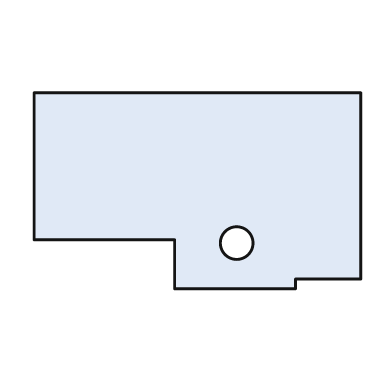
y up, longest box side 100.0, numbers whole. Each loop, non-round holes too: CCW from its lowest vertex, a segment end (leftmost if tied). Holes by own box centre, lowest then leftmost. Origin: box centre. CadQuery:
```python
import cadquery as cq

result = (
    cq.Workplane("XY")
    .moveTo(-7.0, -30.0)
    .lineTo(30.0, -30.0)
    .lineTo(30.0, -27.0)
    .lineTo(50.0, -27.0)
    .lineTo(50.0, 30.0)
    .lineTo(-50.0, 30.0)
    .lineTo(-50.0, -15.0)
    .lineTo(-7.0, -15.0)
    .close()
    .moveTo(12.0, -16.0)
    .circle(5.0)
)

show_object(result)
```